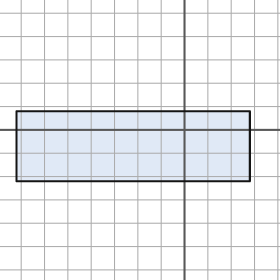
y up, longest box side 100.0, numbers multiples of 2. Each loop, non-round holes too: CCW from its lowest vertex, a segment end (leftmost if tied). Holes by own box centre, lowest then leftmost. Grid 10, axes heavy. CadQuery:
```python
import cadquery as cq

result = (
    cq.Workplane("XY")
    .moveTo(-72.0, -22.0)
    .lineTo(28.0, -22.0)
    .lineTo(28.0, 8.0)
    .lineTo(-72.0, 8.0)
    .close()
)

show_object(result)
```